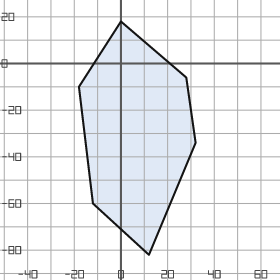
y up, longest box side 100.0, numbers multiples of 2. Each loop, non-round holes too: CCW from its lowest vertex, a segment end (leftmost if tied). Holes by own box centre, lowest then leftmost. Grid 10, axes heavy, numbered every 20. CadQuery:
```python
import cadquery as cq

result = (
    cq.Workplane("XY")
    .moveTo(12.0, -82.0)
    .lineTo(32.0, -34.0)
    .lineTo(28.0, -6.0)
    .lineTo(0.0, 18.0)
    .lineTo(-18.0, -10.0)
    .lineTo(-12.0, -60.0)
    .close()
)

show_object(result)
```